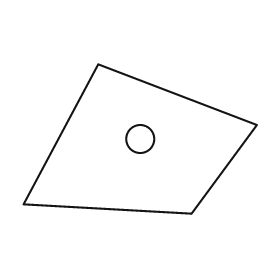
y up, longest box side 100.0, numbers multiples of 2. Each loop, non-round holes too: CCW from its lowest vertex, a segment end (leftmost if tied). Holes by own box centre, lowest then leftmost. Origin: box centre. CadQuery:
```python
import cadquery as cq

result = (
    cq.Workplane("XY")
    .moveTo(22.0, -32.0)
    .lineTo(50.0, 6.0)
    .lineTo(-18.0, 32.0)
    .lineTo(-50.0, -28.0)
    .close()
    .moveTo(0.0, 0.0)
    .circle(6.0)
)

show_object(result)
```